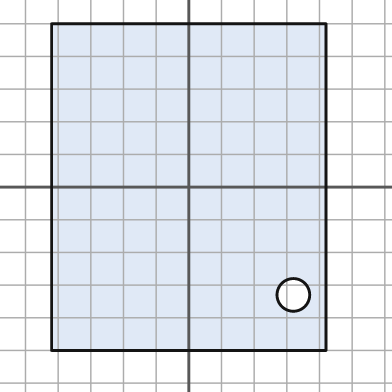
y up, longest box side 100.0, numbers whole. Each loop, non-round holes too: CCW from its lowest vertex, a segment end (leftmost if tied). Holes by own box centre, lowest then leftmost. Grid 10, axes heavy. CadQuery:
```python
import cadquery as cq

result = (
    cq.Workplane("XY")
    .moveTo(-42.0, -50.0)
    .lineTo(42.0, -50.0)
    .lineTo(42.0, 50.0)
    .lineTo(-42.0, 50.0)
    .close()
    .moveTo(32.0, -33.0)
    .circle(5.0)
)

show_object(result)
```